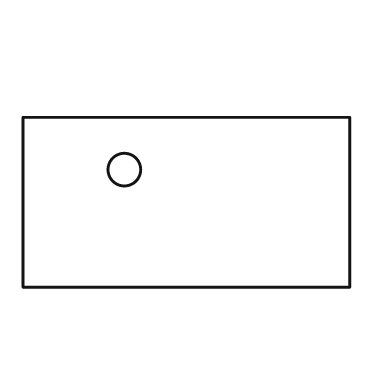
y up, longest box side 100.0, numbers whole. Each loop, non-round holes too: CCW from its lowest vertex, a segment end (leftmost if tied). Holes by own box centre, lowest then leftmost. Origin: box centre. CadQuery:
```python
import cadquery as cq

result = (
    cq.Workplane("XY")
    .moveTo(-50.0, -26.0)
    .lineTo(50.0, -26.0)
    .lineTo(50.0, 26.0)
    .lineTo(-50.0, 26.0)
    .close()
    .moveTo(-19.0, 10.0)
    .circle(5.0)
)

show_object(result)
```